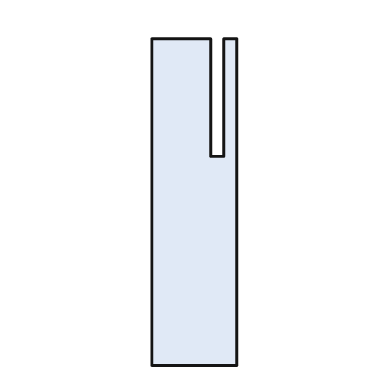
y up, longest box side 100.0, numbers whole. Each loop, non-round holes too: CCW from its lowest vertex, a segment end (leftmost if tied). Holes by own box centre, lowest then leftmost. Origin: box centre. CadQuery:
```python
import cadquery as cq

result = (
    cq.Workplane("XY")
    .moveTo(-13.0, -50.0)
    .lineTo(13.0, -50.0)
    .lineTo(13.0, 50.0)
    .lineTo(9.0, 50.0)
    .lineTo(9.0, 14.0)
    .lineTo(5.0, 14.0)
    .lineTo(5.0, 50.0)
    .lineTo(-13.0, 50.0)
    .close()
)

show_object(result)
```